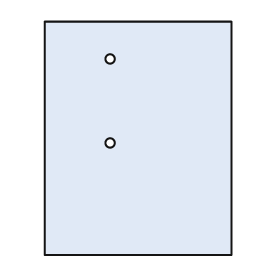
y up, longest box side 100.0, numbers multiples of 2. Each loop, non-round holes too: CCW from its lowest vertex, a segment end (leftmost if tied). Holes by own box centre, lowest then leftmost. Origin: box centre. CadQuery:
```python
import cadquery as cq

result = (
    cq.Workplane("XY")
    .moveTo(-40.0, -50.0)
    .lineTo(40.0, -50.0)
    .lineTo(40.0, 50.0)
    .lineTo(-40.0, 50.0)
    .close()
    .moveTo(-12.0, -2.0)
    .circle(2.0)
    .moveTo(-12.0, 34.0)
    .circle(2.0)
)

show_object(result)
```